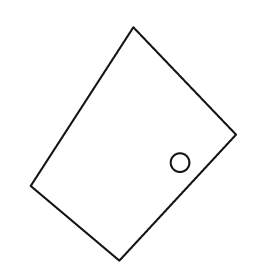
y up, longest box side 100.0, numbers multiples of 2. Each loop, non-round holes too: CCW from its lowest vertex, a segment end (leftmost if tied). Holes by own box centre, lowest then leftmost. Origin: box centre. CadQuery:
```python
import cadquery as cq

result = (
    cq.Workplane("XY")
    .moveTo(-6.0, -50.0)
    .lineTo(44.0, 4.0)
    .lineTo(0.0, 50.0)
    .lineTo(-44.0, -18.0)
    .close()
    .moveTo(20.0, -8.0)
    .circle(4.0)
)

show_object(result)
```